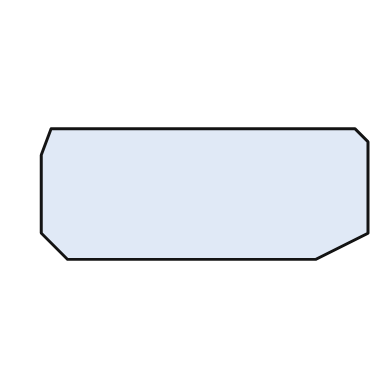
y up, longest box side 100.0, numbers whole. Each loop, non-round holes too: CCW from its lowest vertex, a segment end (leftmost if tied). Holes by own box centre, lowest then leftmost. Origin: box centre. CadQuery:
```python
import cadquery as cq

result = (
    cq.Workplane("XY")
    .moveTo(-42.0, -20.0)
    .lineTo(34.0, -20.0)
    .lineTo(50.0, -12.0)
    .lineTo(50.0, 16.0)
    .lineTo(46.0, 20.0)
    .lineTo(-47.0, 20.0)
    .lineTo(-50.0, 12.0)
    .lineTo(-50.0, -12.0)
    .close()
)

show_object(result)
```